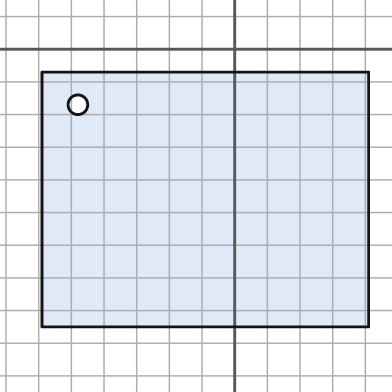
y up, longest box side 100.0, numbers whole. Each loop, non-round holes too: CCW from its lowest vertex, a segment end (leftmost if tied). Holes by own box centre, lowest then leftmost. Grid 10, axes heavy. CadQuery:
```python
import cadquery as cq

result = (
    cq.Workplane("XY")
    .moveTo(-59.0, -85.0)
    .lineTo(41.0, -85.0)
    .lineTo(41.0, -7.0)
    .lineTo(-59.0, -7.0)
    .close()
    .moveTo(-48.0, -17.0)
    .circle(3.0)
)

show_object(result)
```